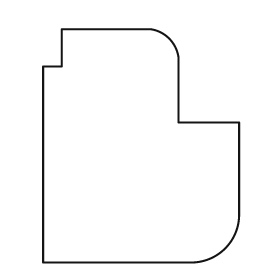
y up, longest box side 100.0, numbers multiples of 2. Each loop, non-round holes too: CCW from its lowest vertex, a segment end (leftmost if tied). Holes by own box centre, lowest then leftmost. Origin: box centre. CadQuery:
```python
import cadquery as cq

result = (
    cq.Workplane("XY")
    .moveTo(-42.0, -50.0)
    .lineTo(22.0, -50.0)
    .threePointArc((36.0, -44.0), (42.0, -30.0))
    .lineTo(42.0, 10.0)
    .lineTo(16.0, 10.0)
    .lineTo(16.0, 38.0)
    .threePointArc((12.0, 46.0), (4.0, 50.0))
    .lineTo(-34.0, 50.0)
    .lineTo(-34.0, 34.0)
    .lineTo(-42.0, 34.0)
    .close()
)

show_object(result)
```